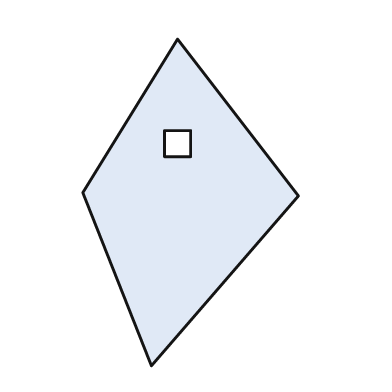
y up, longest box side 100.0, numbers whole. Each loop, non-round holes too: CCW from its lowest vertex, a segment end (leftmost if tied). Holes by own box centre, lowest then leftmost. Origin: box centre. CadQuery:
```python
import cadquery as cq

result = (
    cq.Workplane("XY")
    .moveTo(-12.0, -50.0)
    .lineTo(33.0, 2.0)
    .lineTo(-4.0, 50.0)
    .lineTo(-33.0, 3.0)
    .close()
    .moveTo(-8.0, 14.0)
    .lineTo(0.0, 14.0)
    .lineTo(0.0, 22.0)
    .lineTo(-8.0, 22.0)
    .close()
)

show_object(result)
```